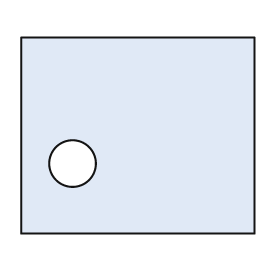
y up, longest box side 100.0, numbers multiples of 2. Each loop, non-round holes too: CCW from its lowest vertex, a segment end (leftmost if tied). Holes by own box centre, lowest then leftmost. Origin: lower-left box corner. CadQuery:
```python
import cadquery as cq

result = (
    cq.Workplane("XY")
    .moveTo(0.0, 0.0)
    .lineTo(100.0, 0.0)
    .lineTo(100.0, 84.0)
    .lineTo(0.0, 84.0)
    .close()
    .moveTo(22.0, 30.0)
    .circle(10.0)
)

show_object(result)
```